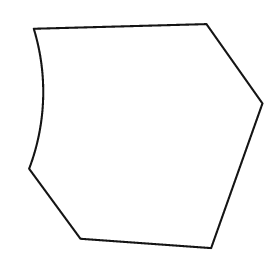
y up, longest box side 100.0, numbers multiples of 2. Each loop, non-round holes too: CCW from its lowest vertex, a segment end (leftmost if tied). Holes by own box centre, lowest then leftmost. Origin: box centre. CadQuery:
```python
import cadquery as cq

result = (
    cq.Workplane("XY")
    .moveTo(28.0, -48.0)
    .lineTo(50.0, 14.0)
    .lineTo(26.0, 48.0)
    .lineTo(-48.0, 46.0)
    .threePointArc((-44.0, 16.0), (-50.0, -14.0))
    .lineTo(-28.0, -44.0)
    .close()
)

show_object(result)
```